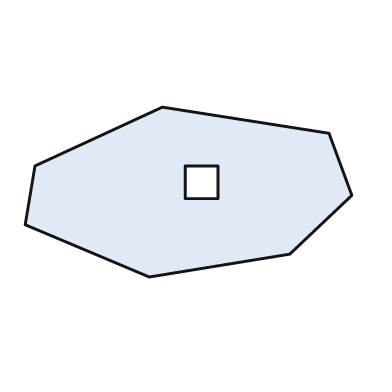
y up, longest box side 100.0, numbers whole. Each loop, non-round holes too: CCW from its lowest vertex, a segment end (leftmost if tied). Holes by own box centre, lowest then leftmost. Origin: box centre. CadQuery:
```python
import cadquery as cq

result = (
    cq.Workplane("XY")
    .moveTo(-12.0, -26.0)
    .lineTo(31.0, -19.0)
    .lineTo(50.0, -1.0)
    .lineTo(43.0, 18.0)
    .lineTo(-8.0, 26.0)
    .lineTo(-47.0, 8.0)
    .lineTo(-50.0, -10.0)
    .close()
    .moveTo(-1.0, -2.0)
    .lineTo(9.0, -2.0)
    .lineTo(9.0, 8.0)
    .lineTo(-1.0, 8.0)
    .close()
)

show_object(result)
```